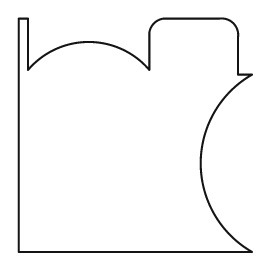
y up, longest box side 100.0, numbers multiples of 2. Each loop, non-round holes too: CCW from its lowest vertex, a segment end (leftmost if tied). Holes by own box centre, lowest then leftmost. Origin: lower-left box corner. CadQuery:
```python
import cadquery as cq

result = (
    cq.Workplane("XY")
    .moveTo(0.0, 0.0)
    .lineTo(100.0, 0.0)
    .threePointArc((78.0, 38.0), (100.0, 76.0))
    .lineTo(94.0, 76.0)
    .lineTo(94.0, 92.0)
    .threePointArc((92.0, 98.0), (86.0, 100.0))
    .lineTo(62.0, 100.0)
    .threePointArc((58.0, 98.0), (56.0, 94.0))
    .lineTo(56.0, 78.0)
    .threePointArc((30.0, 90.0), (4.0, 78.0))
    .lineTo(4.0, 100.0)
    .lineTo(0.0, 100.0)
    .close()
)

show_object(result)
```